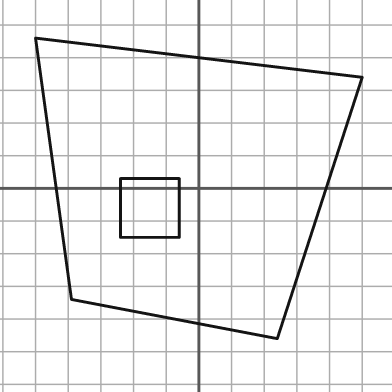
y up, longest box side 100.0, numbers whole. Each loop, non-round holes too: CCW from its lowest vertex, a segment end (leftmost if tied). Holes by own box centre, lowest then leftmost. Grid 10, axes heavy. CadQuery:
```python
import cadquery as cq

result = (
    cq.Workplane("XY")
    .moveTo(24.0, -46.0)
    .lineTo(50.0, 34.0)
    .lineTo(-50.0, 46.0)
    .lineTo(-39.0, -34.0)
    .close()
    .moveTo(-24.0, -15.0)
    .lineTo(-6.0, -15.0)
    .lineTo(-6.0, 3.0)
    .lineTo(-24.0, 3.0)
    .close()
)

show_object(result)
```